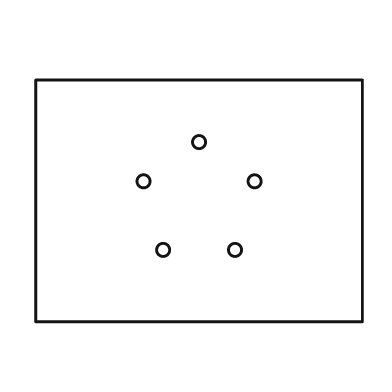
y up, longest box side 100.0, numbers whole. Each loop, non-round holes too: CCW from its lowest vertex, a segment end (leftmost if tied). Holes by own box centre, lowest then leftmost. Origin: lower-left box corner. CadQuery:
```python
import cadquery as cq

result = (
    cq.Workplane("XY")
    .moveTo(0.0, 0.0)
    .lineTo(100.0, 0.0)
    .lineTo(100.0, 74.0)
    .lineTo(0.0, 74.0)
    .close()
    .moveTo(39.0, 22.0)
    .circle(2.0)
    .moveTo(61.0, 22.0)
    .circle(2.0)
    .moveTo(33.0, 43.0)
    .circle(2.0)
    .moveTo(67.0, 43.0)
    .circle(2.0)
    .moveTo(50.0, 55.0)
    .circle(2.0)
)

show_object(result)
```